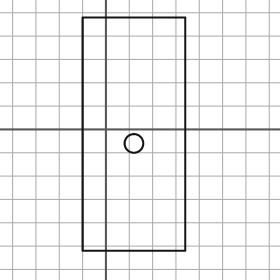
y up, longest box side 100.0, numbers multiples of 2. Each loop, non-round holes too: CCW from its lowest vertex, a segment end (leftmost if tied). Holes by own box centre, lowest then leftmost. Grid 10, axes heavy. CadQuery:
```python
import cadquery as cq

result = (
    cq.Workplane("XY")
    .moveTo(-10.0, -52.0)
    .lineTo(34.0, -52.0)
    .lineTo(34.0, 48.0)
    .lineTo(-10.0, 48.0)
    .close()
    .moveTo(12.0, -6.0)
    .circle(4.0)
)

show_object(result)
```